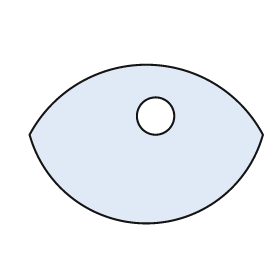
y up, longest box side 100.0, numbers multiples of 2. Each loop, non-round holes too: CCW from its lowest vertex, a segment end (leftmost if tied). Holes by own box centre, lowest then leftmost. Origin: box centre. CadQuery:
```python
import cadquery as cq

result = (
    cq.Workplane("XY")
    .moveTo(-50.0, 4.0)
    .threePointArc((0.0, -34.0), (50.0, 4.0))
    .threePointArc((0.0, 34.0), (-50.0, 4.0))
    .close()
    .moveTo(4.0, 12.0)
    .circle(8.0)
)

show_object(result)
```